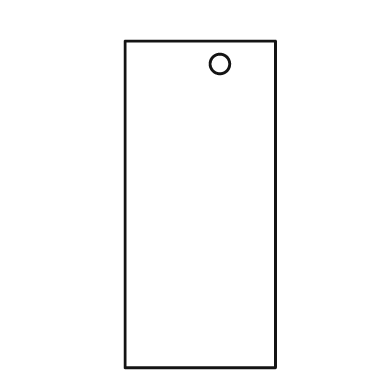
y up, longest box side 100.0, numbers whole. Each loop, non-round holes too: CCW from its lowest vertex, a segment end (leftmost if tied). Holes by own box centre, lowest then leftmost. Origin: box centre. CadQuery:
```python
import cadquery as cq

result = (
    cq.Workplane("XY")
    .moveTo(-23.0, -50.0)
    .lineTo(23.0, -50.0)
    .lineTo(23.0, 50.0)
    .lineTo(-23.0, 50.0)
    .close()
    .moveTo(6.0, 43.0)
    .circle(3.0)
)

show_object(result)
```